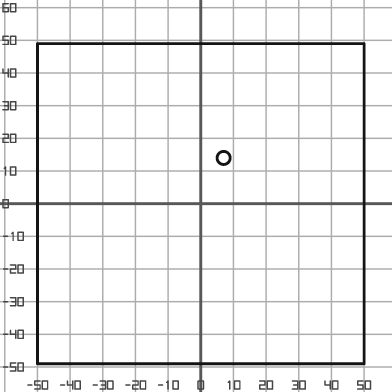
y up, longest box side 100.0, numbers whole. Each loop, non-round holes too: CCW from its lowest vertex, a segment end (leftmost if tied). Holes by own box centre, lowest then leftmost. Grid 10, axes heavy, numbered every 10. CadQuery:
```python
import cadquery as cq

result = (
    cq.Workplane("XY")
    .moveTo(-50.0, -49.0)
    .lineTo(50.0, -49.0)
    .lineTo(50.0, 49.0)
    .lineTo(-50.0, 49.0)
    .close()
    .moveTo(7.0, 14.0)
    .circle(2.0)
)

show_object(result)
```